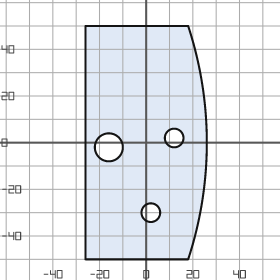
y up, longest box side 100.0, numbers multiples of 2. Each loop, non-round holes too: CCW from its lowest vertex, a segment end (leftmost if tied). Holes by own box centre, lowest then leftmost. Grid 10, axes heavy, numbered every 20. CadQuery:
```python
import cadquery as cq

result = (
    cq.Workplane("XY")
    .moveTo(-26.0, -50.0)
    .lineTo(18.0, -50.0)
    .threePointArc((26.0, 0.0), (18.0, 50.0))
    .lineTo(-26.0, 50.0)
    .close()
    .moveTo(2.0, -30.0)
    .circle(4.0)
    .moveTo(-16.0, -2.0)
    .circle(6.0)
    .moveTo(12.0, 2.0)
    .circle(4.0)
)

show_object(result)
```